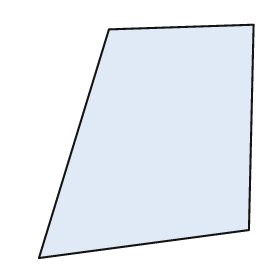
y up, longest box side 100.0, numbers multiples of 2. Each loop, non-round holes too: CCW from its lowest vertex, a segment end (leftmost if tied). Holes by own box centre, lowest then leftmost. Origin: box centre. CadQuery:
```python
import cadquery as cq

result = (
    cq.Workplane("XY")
    .moveTo(-46.0, -50.0)
    .lineTo(44.0, -38.0)
    .lineTo(46.0, 50.0)
    .lineTo(-16.0, 48.0)
    .close()
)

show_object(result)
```